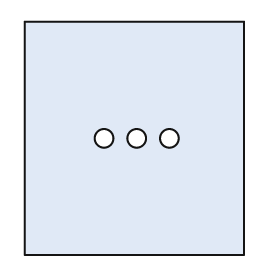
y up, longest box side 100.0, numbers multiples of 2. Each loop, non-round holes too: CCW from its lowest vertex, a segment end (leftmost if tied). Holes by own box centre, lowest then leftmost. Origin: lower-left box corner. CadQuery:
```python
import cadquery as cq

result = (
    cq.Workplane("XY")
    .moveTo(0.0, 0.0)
    .lineTo(94.0, 0.0)
    .lineTo(94.0, 100.0)
    .lineTo(0.0, 100.0)
    .close()
    .moveTo(34.0, 50.0)
    .circle(4.0)
    .moveTo(48.0, 50.0)
    .circle(4.0)
    .moveTo(62.0, 50.0)
    .circle(4.0)
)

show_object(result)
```